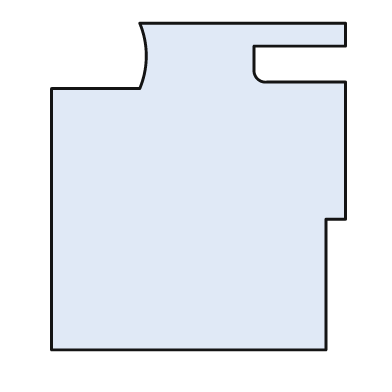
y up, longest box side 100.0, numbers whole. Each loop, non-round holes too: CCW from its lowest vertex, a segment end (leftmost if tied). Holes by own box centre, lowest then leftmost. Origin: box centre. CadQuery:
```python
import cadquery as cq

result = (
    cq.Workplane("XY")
    .moveTo(-45.0, -50.0)
    .lineTo(39.0, -50.0)
    .lineTo(39.0, -10.0)
    .lineTo(45.0, -10.0)
    .lineTo(45.0, 32.0)
    .lineTo(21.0, 32.0)
    .threePointArc((18.0, 33.0), (17.0, 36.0))
    .lineTo(17.0, 43.0)
    .lineTo(45.0, 43.0)
    .lineTo(45.0, 50.0)
    .lineTo(-18.0, 50.0)
    .threePointArc((-16.0, 40.0), (-18.0, 30.0))
    .lineTo(-45.0, 30.0)
    .close()
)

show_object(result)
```